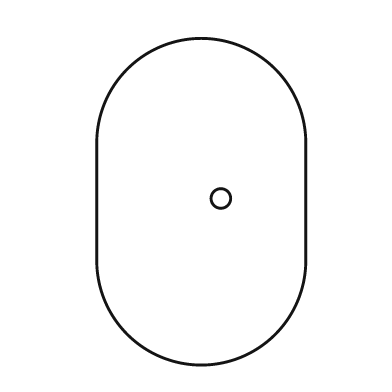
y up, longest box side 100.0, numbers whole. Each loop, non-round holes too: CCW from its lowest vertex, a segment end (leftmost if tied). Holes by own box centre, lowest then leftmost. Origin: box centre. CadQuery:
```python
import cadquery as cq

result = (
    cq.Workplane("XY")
    .moveTo(-32.0, -18.0)
    .threePointArc((0.0, -50.0), (32.0, -18.0))
    .lineTo(32.0, 18.0)
    .threePointArc((0.0, 50.0), (-32.0, 18.0))
    .close()
    .moveTo(6.0, 1.0)
    .circle(3.0)
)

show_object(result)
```